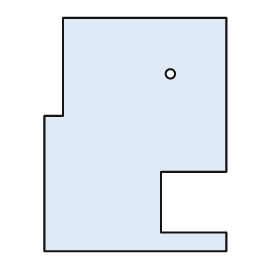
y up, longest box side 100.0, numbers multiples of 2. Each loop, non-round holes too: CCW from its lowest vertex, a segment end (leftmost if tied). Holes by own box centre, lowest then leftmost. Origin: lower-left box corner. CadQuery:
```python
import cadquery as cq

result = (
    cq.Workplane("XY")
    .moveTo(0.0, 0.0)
    .lineTo(78.0, 0.0)
    .lineTo(78.0, 8.0)
    .lineTo(50.0, 8.0)
    .lineTo(50.0, 34.0)
    .lineTo(78.0, 34.0)
    .lineTo(78.0, 100.0)
    .lineTo(8.0, 100.0)
    .lineTo(8.0, 58.0)
    .lineTo(0.0, 58.0)
    .close()
    .moveTo(54.0, 76.0)
    .circle(2.0)
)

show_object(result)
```